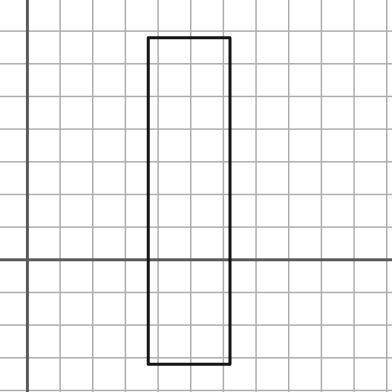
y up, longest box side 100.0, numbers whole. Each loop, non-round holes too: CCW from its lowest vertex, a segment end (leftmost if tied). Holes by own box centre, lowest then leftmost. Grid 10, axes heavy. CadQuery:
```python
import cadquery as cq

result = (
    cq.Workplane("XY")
    .moveTo(37.0, -32.0)
    .lineTo(62.0, -32.0)
    .lineTo(62.0, 68.0)
    .lineTo(37.0, 68.0)
    .close()
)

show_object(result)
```